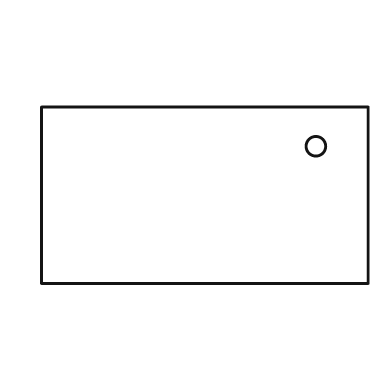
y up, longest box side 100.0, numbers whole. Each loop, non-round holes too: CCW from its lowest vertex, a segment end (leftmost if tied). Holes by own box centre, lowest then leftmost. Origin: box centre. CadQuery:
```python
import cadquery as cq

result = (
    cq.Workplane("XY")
    .moveTo(-50.0, -27.0)
    .lineTo(50.0, -27.0)
    .lineTo(50.0, 27.0)
    .lineTo(-50.0, 27.0)
    .close()
    .moveTo(34.0, 15.0)
    .circle(3.0)
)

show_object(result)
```